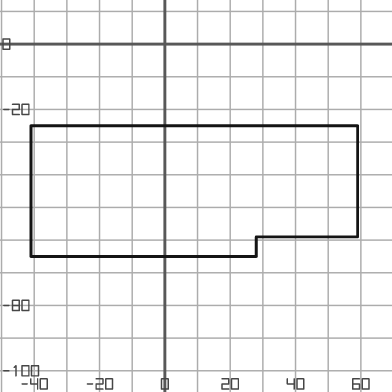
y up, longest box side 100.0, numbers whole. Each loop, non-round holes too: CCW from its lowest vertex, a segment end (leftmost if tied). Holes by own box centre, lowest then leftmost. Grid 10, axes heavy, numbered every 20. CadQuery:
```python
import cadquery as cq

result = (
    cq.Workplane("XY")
    .moveTo(-41.0, -65.0)
    .lineTo(28.0, -65.0)
    .lineTo(28.0, -59.0)
    .lineTo(59.0, -59.0)
    .lineTo(59.0, -25.0)
    .lineTo(-41.0, -25.0)
    .close()
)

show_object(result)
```